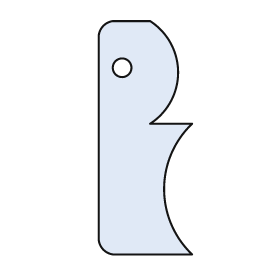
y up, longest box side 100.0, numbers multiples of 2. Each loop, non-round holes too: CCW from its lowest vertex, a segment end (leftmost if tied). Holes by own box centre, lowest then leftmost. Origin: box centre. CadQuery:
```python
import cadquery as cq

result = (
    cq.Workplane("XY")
    .moveTo(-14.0, -50.0)
    .lineTo(20.0, -50.0)
    .threePointArc((8.0, -22.0), (20.0, 6.0))
    .lineTo(2.0, 6.0)
    .threePointArc((14.0, 28.0), (2.0, 50.0))
    .lineTo(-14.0, 50.0)
    .threePointArc((-18.0, 48.0), (-20.0, 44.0))
    .lineTo(-20.0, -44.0)
    .threePointArc((-18.0, -48.0), (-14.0, -50.0))
    .close()
    .moveTo(-10.0, 30.0)
    .circle(4.0)
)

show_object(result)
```